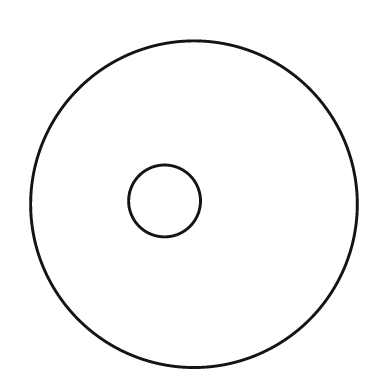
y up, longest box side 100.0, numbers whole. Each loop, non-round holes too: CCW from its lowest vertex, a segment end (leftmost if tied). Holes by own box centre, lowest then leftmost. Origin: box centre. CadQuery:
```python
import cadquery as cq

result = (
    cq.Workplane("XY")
    .moveTo(0.0, 0.0)
    .circle(50.0)
    .moveTo(-9.0, 1.0)
    .circle(11.0)
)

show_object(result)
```